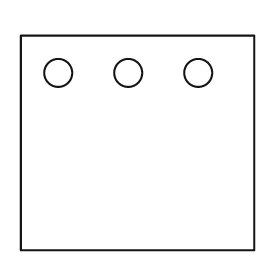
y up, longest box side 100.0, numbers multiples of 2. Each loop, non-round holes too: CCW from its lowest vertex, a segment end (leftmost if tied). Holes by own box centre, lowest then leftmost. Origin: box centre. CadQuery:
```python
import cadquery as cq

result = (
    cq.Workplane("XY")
    .moveTo(-50.0, -46.0)
    .lineTo(50.0, -46.0)
    .lineTo(50.0, 46.0)
    .lineTo(-50.0, 46.0)
    .close()
    .moveTo(-34.0, 30.0)
    .circle(6.0)
    .moveTo(-4.0, 30.0)
    .circle(6.0)
    .moveTo(26.0, 30.0)
    .circle(6.0)
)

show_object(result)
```